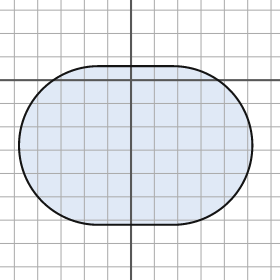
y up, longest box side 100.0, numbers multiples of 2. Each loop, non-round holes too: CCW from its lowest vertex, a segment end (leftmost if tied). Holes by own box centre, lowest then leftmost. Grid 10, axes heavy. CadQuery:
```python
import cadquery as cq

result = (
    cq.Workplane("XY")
    .moveTo(-14.0, -62.0)
    .lineTo(18.0, -62.0)
    .threePointArc((52.0, -28.0), (18.0, 6.0))
    .lineTo(-14.0, 6.0)
    .threePointArc((-48.0, -28.0), (-14.0, -62.0))
    .close()
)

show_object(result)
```